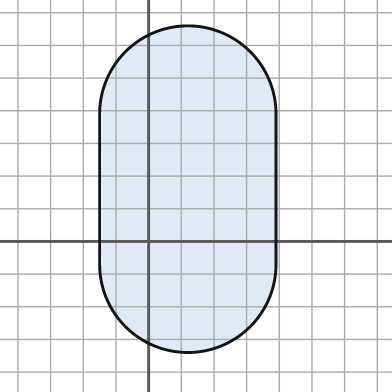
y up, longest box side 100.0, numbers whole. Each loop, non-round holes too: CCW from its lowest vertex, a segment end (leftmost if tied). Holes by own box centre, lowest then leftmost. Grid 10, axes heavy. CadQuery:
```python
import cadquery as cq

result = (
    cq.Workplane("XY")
    .moveTo(-15.0, -7.0)
    .threePointArc((12.0, -34.0), (39.0, -7.0))
    .lineTo(39.0, 39.0)
    .threePointArc((12.0, 66.0), (-15.0, 39.0))
    .close()
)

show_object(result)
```